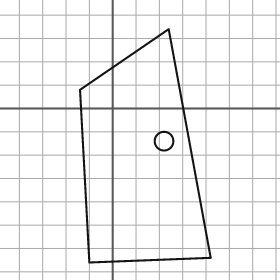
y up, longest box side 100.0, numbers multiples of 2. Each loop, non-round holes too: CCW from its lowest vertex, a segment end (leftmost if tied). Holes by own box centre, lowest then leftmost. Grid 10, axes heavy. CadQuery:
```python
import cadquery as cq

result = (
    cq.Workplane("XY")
    .moveTo(-10.0, -66.0)
    .lineTo(42.0, -64.0)
    .lineTo(24.0, 34.0)
    .lineTo(-14.0, 8.0)
    .close()
    .moveTo(22.0, -14.0)
    .circle(4.0)
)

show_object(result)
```